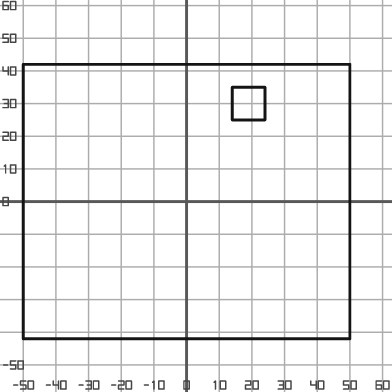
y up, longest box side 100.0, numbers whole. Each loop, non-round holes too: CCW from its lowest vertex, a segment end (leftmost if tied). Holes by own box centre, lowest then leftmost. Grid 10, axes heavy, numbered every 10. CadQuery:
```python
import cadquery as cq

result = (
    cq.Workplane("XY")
    .moveTo(-50.0, -42.0)
    .lineTo(50.0, -42.0)
    .lineTo(50.0, 42.0)
    .lineTo(-50.0, 42.0)
    .close()
    .moveTo(14.0, 25.0)
    .lineTo(24.0, 25.0)
    .lineTo(24.0, 35.0)
    .lineTo(14.0, 35.0)
    .close()
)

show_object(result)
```